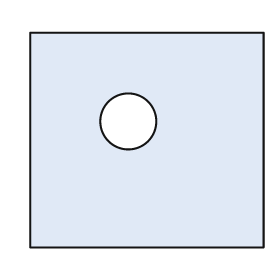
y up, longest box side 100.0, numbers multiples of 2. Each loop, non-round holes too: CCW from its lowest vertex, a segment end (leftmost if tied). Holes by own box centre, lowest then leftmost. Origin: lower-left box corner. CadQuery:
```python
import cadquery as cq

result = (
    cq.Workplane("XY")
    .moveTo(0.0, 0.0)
    .lineTo(100.0, 0.0)
    .lineTo(100.0, 92.0)
    .lineTo(0.0, 92.0)
    .close()
    .moveTo(42.0, 54.0)
    .circle(12.0)
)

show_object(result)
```